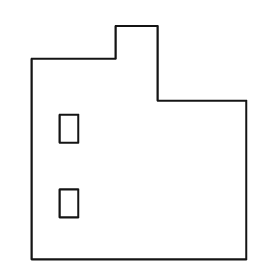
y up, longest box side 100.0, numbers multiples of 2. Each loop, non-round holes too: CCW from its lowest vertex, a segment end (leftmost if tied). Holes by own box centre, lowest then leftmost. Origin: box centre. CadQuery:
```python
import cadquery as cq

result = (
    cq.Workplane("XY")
    .moveTo(-46.0, -50.0)
    .lineTo(46.0, -50.0)
    .lineTo(46.0, 18.0)
    .lineTo(8.0, 18.0)
    .lineTo(8.0, 50.0)
    .lineTo(-10.0, 50.0)
    .lineTo(-10.0, 36.0)
    .lineTo(-46.0, 36.0)
    .close()
    .moveTo(-34.0, -32.0)
    .lineTo(-26.0, -32.0)
    .lineTo(-26.0, -20.0)
    .lineTo(-34.0, -20.0)
    .close()
    .moveTo(-34.0, 0.0)
    .lineTo(-26.0, 0.0)
    .lineTo(-26.0, 12.0)
    .lineTo(-34.0, 12.0)
    .close()
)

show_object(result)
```